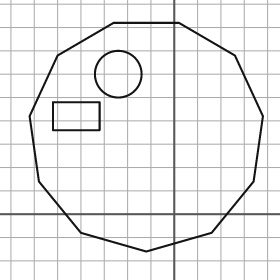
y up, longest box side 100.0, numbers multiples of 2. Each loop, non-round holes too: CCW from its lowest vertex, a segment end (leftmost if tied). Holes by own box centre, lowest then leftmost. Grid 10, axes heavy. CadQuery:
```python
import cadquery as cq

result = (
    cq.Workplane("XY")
    .moveTo(-12.0, -16.0)
    .lineTo(16.0, -8.0)
    .lineTo(34.0, 14.0)
    .lineTo(38.0, 42.0)
    .lineTo(26.0, 68.0)
    .lineTo(2.0, 82.0)
    .lineTo(-26.0, 82.0)
    .lineTo(-50.0, 68.0)
    .lineTo(-62.0, 42.0)
    .lineTo(-58.0, 14.0)
    .lineTo(-40.0, -8.0)
    .close()
    .moveTo(-52.0, 36.0)
    .lineTo(-32.0, 36.0)
    .lineTo(-32.0, 48.0)
    .lineTo(-52.0, 48.0)
    .close()
    .moveTo(-24.0, 60.0)
    .circle(10.0)
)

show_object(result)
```